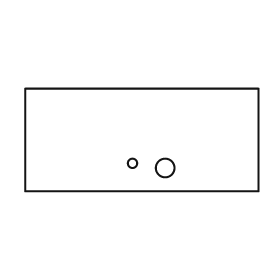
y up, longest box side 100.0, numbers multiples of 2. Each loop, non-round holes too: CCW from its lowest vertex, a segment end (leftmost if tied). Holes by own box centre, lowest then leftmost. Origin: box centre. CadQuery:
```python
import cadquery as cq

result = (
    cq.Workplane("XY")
    .moveTo(-50.0, -22.0)
    .lineTo(50.0, -22.0)
    .lineTo(50.0, 22.0)
    .lineTo(-50.0, 22.0)
    .close()
    .moveTo(10.0, -12.0)
    .circle(4.0)
    .moveTo(-4.0, -10.0)
    .circle(2.0)
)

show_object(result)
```